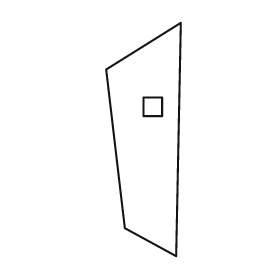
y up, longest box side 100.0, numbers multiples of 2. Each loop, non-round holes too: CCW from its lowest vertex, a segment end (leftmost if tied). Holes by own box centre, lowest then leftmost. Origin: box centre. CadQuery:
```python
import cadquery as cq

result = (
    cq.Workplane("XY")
    .moveTo(14.0, -50.0)
    .lineTo(16.0, 50.0)
    .lineTo(-16.0, 30.0)
    .lineTo(-8.0, -38.0)
    .close()
    .moveTo(0.0, 10.0)
    .lineTo(8.0, 10.0)
    .lineTo(8.0, 18.0)
    .lineTo(0.0, 18.0)
    .close()
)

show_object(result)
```